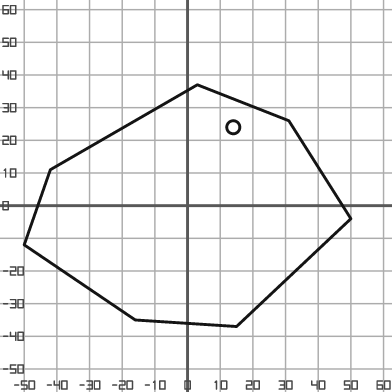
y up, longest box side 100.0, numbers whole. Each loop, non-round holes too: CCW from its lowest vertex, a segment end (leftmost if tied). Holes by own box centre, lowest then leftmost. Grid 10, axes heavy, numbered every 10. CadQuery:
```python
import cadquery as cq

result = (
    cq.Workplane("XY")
    .moveTo(15.0, -37.0)
    .lineTo(50.0, -4.0)
    .lineTo(31.0, 26.0)
    .lineTo(3.0, 37.0)
    .lineTo(-42.0, 11.0)
    .lineTo(-50.0, -12.0)
    .lineTo(-16.0, -35.0)
    .close()
    .moveTo(14.0, 24.0)
    .circle(2.0)
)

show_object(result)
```